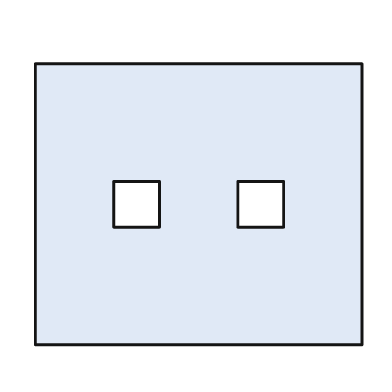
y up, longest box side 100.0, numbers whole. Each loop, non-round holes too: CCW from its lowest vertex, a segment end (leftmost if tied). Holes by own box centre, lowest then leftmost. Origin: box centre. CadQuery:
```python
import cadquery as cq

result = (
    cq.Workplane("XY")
    .moveTo(-50.0, -43.0)
    .lineTo(50.0, -43.0)
    .lineTo(50.0, 43.0)
    .lineTo(-50.0, 43.0)
    .close()
    .moveTo(-26.0, -7.0)
    .lineTo(-12.0, -7.0)
    .lineTo(-12.0, 7.0)
    .lineTo(-26.0, 7.0)
    .close()
    .moveTo(12.0, -7.0)
    .lineTo(26.0, -7.0)
    .lineTo(26.0, 7.0)
    .lineTo(12.0, 7.0)
    .close()
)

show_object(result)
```